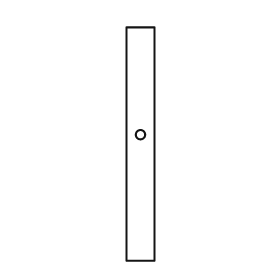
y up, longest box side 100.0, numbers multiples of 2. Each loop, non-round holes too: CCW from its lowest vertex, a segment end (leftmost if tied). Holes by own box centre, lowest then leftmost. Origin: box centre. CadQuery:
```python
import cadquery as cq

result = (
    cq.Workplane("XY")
    .moveTo(-6.0, -50.0)
    .lineTo(6.0, -50.0)
    .lineTo(6.0, 50.0)
    .lineTo(-6.0, 50.0)
    .close()
    .moveTo(0.0, 4.0)
    .circle(2.0)
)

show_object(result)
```